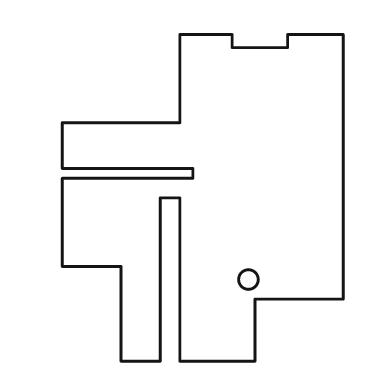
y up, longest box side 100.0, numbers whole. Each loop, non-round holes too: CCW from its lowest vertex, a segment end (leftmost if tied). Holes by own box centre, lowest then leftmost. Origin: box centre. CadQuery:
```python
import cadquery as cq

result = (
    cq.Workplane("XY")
    .moveTo(-25.0, -50.0)
    .lineTo(-13.0, -50.0)
    .lineTo(-13.0, 0.0)
    .lineTo(-7.0, 0.0)
    .lineTo(-7.0, -50.0)
    .lineTo(16.0, -50.0)
    .lineTo(16.0, -31.0)
    .lineTo(43.0, -31.0)
    .lineTo(43.0, 50.0)
    .lineTo(26.0, 50.0)
    .lineTo(26.0, 46.0)
    .lineTo(9.0, 46.0)
    .lineTo(9.0, 50.0)
    .lineTo(-7.0, 50.0)
    .lineTo(-7.0, 23.0)
    .lineTo(-43.0, 23.0)
    .lineTo(-43.0, 9.0)
    .lineTo(-3.0, 9.0)
    .lineTo(-3.0, 6.0)
    .lineTo(-43.0, 6.0)
    .lineTo(-43.0, -21.0)
    .lineTo(-25.0, -21.0)
    .close()
    .moveTo(14.0, -25.0)
    .circle(3.0)
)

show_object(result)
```